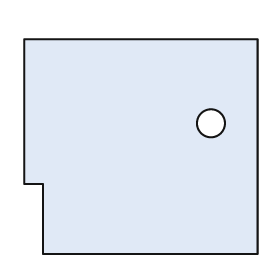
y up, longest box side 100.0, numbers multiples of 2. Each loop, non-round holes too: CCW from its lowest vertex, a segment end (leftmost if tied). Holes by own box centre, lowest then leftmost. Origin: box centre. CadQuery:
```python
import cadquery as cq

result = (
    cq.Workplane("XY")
    .moveTo(-42.0, -46.0)
    .lineTo(50.0, -46.0)
    .lineTo(50.0, 46.0)
    .lineTo(-50.0, 46.0)
    .lineTo(-50.0, -16.0)
    .lineTo(-42.0, -16.0)
    .close()
    .moveTo(30.0, 10.0)
    .circle(6.0)
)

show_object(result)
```